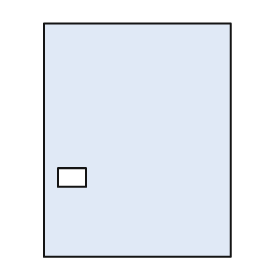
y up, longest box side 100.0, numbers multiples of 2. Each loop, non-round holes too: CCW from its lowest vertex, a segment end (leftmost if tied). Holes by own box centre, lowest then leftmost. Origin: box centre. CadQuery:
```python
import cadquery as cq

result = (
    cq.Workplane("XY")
    .moveTo(-40.0, -50.0)
    .lineTo(40.0, -50.0)
    .lineTo(40.0, 50.0)
    .lineTo(-40.0, 50.0)
    .close()
    .moveTo(-34.0, -20.0)
    .lineTo(-22.0, -20.0)
    .lineTo(-22.0, -12.0)
    .lineTo(-34.0, -12.0)
    .close()
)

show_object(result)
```